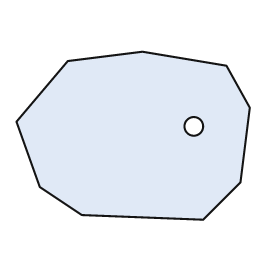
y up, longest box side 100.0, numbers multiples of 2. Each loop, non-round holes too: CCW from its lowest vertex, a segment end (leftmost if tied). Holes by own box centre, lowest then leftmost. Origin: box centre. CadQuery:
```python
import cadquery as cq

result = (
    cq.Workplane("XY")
    .moveTo(30.0, -36.0)
    .lineTo(46.0, -20.0)
    .lineTo(50.0, 12.0)
    .lineTo(40.0, 30.0)
    .lineTo(4.0, 36.0)
    .lineTo(-28.0, 32.0)
    .lineTo(-50.0, 6.0)
    .lineTo(-40.0, -22.0)
    .lineTo(-22.0, -34.0)
    .close()
    .moveTo(26.0, 4.0)
    .circle(4.0)
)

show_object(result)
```